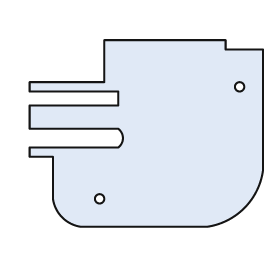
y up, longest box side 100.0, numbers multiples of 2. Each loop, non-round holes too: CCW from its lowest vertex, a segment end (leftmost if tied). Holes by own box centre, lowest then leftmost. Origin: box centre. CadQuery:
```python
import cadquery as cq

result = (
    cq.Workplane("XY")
    .moveTo(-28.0, -40.0)
    .lineTo(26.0, -40.0)
    .threePointArc((42.0, -32.0), (50.0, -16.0))
    .lineTo(50.0, 36.0)
    .lineTo(34.0, 36.0)
    .lineTo(34.0, 40.0)
    .lineTo(-18.0, 40.0)
    .lineTo(-18.0, 22.0)
    .lineTo(-50.0, 22.0)
    .lineTo(-50.0, 18.0)
    .lineTo(-12.0, 18.0)
    .lineTo(-12.0, 12.0)
    .lineTo(-50.0, 12.0)
    .lineTo(-50.0, 2.0)
    .lineTo(-12.0, 2.0)
    .threePointArc((-10.0, -2.0), (-12.0, -6.0))
    .lineTo(-50.0, -6.0)
    .lineTo(-50.0, -10.0)
    .lineTo(-40.0, -10.0)
    .lineTo(-40.0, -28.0)
    .threePointArc((-36.0, -36.0), (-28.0, -40.0))
    .close()
    .moveTo(-20.0, -28.0)
    .circle(2.0)
    .moveTo(40.0, 20.0)
    .circle(2.0)
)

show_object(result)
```